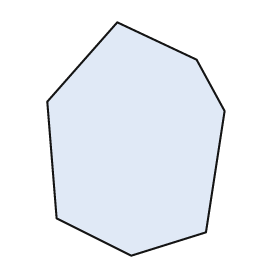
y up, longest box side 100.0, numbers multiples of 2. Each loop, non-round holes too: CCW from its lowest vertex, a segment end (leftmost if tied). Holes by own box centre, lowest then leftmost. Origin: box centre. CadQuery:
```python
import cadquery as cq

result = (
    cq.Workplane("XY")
    .moveTo(-2.0, -50.0)
    .lineTo(30.0, -40.0)
    .lineTo(38.0, 12.0)
    .lineTo(26.0, 34.0)
    .lineTo(-8.0, 50.0)
    .lineTo(-38.0, 16.0)
    .lineTo(-34.0, -34.0)
    .close()
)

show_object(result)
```